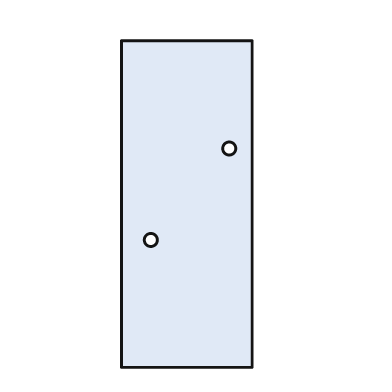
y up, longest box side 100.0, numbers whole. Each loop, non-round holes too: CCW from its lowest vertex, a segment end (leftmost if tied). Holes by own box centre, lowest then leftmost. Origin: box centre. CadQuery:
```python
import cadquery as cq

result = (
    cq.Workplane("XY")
    .moveTo(-20.0, -50.0)
    .lineTo(20.0, -50.0)
    .lineTo(20.0, 50.0)
    .lineTo(-20.0, 50.0)
    .close()
    .moveTo(-11.0, -11.0)
    .circle(2.0)
    .moveTo(13.0, 17.0)
    .circle(2.0)
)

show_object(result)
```